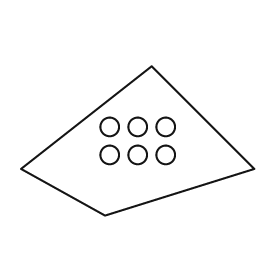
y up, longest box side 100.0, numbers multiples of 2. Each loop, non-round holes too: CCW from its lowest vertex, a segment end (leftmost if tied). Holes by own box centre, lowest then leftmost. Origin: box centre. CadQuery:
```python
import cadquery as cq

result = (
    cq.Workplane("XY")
    .moveTo(-14.0, -32.0)
    .lineTo(50.0, -12.0)
    .lineTo(6.0, 32.0)
    .lineTo(-50.0, -12.0)
    .close()
    .moveTo(-12.0, -6.0)
    .circle(4.0)
    .moveTo(0.0, -6.0)
    .circle(4.0)
    .moveTo(12.0, -6.0)
    .circle(4.0)
    .moveTo(-12.0, 6.0)
    .circle(4.0)
    .moveTo(0.0, 6.0)
    .circle(4.0)
    .moveTo(12.0, 6.0)
    .circle(4.0)
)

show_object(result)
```